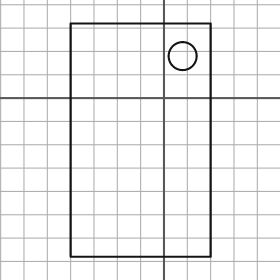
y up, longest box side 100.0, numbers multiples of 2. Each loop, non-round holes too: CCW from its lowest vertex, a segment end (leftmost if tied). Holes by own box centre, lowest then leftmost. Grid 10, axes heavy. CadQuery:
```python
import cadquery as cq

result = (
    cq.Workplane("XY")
    .moveTo(-40.0, -68.0)
    .lineTo(20.0, -68.0)
    .lineTo(20.0, 32.0)
    .lineTo(-40.0, 32.0)
    .close()
    .moveTo(8.0, 18.0)
    .circle(6.0)
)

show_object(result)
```